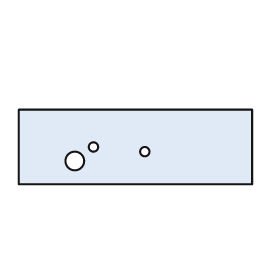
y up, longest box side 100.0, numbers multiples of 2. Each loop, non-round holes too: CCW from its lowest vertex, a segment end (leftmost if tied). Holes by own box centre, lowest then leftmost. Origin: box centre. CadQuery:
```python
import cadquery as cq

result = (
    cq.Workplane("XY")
    .moveTo(-50.0, -16.0)
    .lineTo(50.0, -16.0)
    .lineTo(50.0, 16.0)
    .lineTo(-50.0, 16.0)
    .close()
    .moveTo(-26.0, -6.0)
    .circle(4.0)
    .moveTo(4.0, -2.0)
    .circle(2.0)
    .moveTo(-18.0, 0.0)
    .circle(2.0)
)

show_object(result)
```